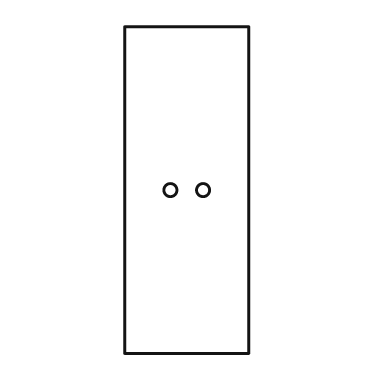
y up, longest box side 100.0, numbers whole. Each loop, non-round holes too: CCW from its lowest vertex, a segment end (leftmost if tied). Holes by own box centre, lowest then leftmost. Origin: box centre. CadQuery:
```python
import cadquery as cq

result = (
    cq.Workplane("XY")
    .moveTo(-19.0, -50.0)
    .lineTo(19.0, -50.0)
    .lineTo(19.0, 50.0)
    .lineTo(-19.0, 50.0)
    .close()
    .moveTo(-5.0, 0.0)
    .circle(2.0)
    .moveTo(5.0, 0.0)
    .circle(2.0)
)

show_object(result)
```